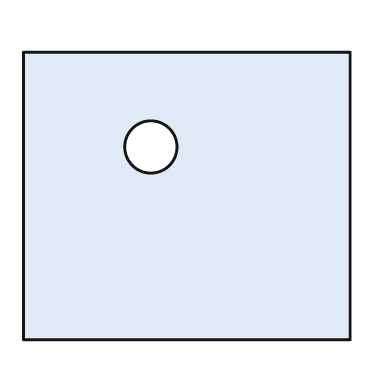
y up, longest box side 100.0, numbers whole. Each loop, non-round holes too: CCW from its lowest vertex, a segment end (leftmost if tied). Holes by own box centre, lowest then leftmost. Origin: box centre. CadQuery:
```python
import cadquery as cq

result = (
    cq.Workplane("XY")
    .moveTo(-50.0, -44.0)
    .lineTo(50.0, -44.0)
    .lineTo(50.0, 44.0)
    .lineTo(-50.0, 44.0)
    .close()
    .moveTo(-11.0, 15.0)
    .circle(8.0)
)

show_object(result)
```